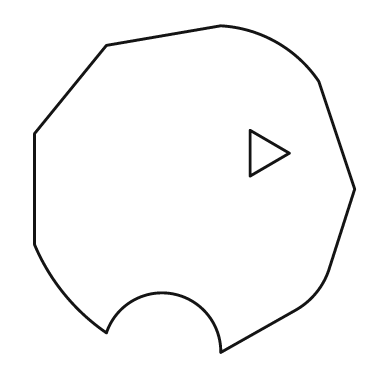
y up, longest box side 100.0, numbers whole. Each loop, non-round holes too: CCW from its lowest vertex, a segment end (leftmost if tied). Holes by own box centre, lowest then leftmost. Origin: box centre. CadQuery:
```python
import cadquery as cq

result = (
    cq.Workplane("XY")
    .moveTo(8.0, -50.0)
    .lineTo(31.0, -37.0)
    .threePointArc((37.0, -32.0), (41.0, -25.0))
    .lineTo(49.0, 0.0)
    .lineTo(38.0, 33.0)
    .threePointArc((25.0, 45.0), (8.0, 50.0))
    .lineTo(-27.0, 44.0)
    .lineTo(-49.0, 17.0)
    .lineTo(-49.0, -17.0)
    .threePointArc((-40.0, -32.0), (-27.0, -44.0))
    .threePointArc((-7.0, -32.0), (8.0, -50.0))
    .close()
    .moveTo(17.0, 4.0)
    .lineTo(29.0, 11.0)
    .lineTo(17.0, 18.0)
    .close()
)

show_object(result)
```